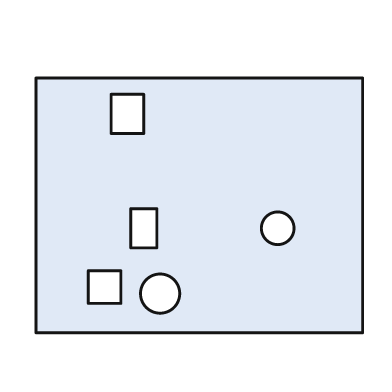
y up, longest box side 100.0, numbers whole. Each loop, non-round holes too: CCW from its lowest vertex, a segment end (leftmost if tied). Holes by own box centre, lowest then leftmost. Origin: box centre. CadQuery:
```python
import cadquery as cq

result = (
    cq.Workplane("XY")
    .moveTo(-50.0, -39.0)
    .lineTo(50.0, -39.0)
    .lineTo(50.0, 39.0)
    .lineTo(-50.0, 39.0)
    .close()
    .moveTo(-12.0, -27.0)
    .circle(6.0)
    .moveTo(-34.0, -30.0)
    .lineTo(-24.0, -30.0)
    .lineTo(-24.0, -20.0)
    .lineTo(-34.0, -20.0)
    .close()
    .moveTo(-21.0, -13.0)
    .lineTo(-13.0, -13.0)
    .lineTo(-13.0, -1.0)
    .lineTo(-21.0, -1.0)
    .close()
    .moveTo(24.0, -7.0)
    .circle(5.0)
    .moveTo(-27.0, 22.0)
    .lineTo(-17.0, 22.0)
    .lineTo(-17.0, 34.0)
    .lineTo(-27.0, 34.0)
    .close()
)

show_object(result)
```